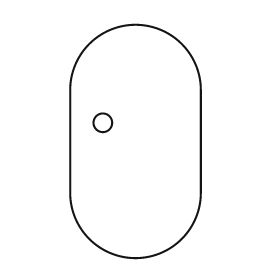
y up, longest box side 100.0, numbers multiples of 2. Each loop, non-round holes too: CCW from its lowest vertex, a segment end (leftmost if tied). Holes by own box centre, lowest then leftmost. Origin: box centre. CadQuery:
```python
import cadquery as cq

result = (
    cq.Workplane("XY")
    .moveTo(-28.0, -22.0)
    .threePointArc((0.0, -50.0), (28.0, -22.0))
    .lineTo(28.0, 22.0)
    .threePointArc((0.0, 50.0), (-28.0, 22.0))
    .close()
    .moveTo(-14.0, 8.0)
    .circle(4.0)
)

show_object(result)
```